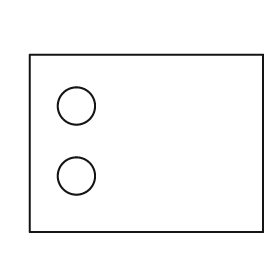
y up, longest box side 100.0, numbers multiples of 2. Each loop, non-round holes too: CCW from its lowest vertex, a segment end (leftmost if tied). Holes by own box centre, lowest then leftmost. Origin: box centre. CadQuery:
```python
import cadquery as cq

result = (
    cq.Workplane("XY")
    .moveTo(-50.0, -38.0)
    .lineTo(50.0, -38.0)
    .lineTo(50.0, 38.0)
    .lineTo(-50.0, 38.0)
    .close()
    .moveTo(-30.0, -14.0)
    .circle(8.0)
    .moveTo(-30.0, 16.0)
    .circle(8.0)
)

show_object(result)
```